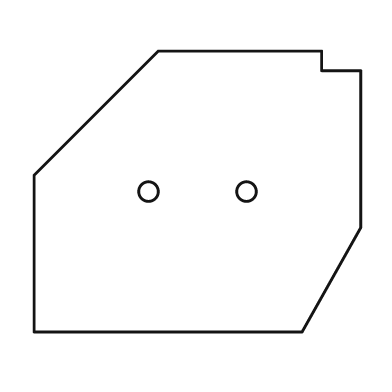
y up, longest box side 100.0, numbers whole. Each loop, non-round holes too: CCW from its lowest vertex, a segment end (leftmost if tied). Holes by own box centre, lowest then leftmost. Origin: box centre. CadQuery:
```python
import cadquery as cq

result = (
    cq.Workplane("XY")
    .moveTo(-50.0, -43.0)
    .lineTo(32.0, -43.0)
    .lineTo(50.0, -11.0)
    .lineTo(50.0, 37.0)
    .lineTo(38.0, 37.0)
    .lineTo(38.0, 43.0)
    .lineTo(-12.0, 43.0)
    .lineTo(-50.0, 5.0)
    .close()
    .moveTo(-15.0, 0.0)
    .circle(3.0)
    .moveTo(15.0, 0.0)
    .circle(3.0)
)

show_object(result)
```